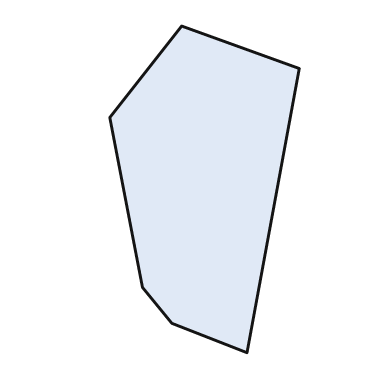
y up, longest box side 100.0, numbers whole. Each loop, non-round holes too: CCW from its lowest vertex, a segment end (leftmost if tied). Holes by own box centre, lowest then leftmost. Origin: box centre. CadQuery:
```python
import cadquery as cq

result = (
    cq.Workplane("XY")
    .moveTo(13.0, -50.0)
    .lineTo(29.0, 37.0)
    .lineTo(-7.0, 50.0)
    .lineTo(-29.0, 22.0)
    .lineTo(-19.0, -30.0)
    .lineTo(-10.0, -41.0)
    .close()
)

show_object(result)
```